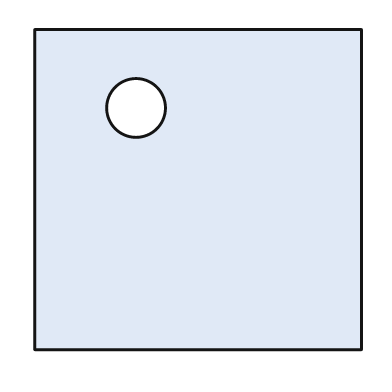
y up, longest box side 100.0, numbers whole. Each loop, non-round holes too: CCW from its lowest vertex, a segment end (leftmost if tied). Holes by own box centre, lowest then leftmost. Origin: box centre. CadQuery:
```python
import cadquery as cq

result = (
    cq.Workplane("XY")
    .moveTo(-50.0, -49.0)
    .lineTo(50.0, -49.0)
    .lineTo(50.0, 49.0)
    .lineTo(-50.0, 49.0)
    .close()
    .moveTo(-19.0, 25.0)
    .circle(9.0)
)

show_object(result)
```